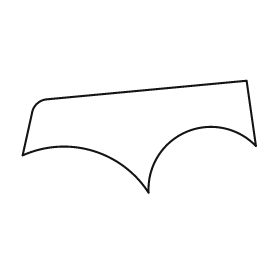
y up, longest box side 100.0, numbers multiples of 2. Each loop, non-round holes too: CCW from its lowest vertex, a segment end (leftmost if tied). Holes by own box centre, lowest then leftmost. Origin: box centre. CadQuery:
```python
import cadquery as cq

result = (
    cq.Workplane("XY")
    .moveTo(4.0, -24.0)
    .threePointArc((20.0, 2.0), (50.0, -4.0))
    .lineTo(46.0, 24.0)
    .lineTo(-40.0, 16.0)
    .threePointArc((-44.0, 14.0), (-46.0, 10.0))
    .lineTo(-50.0, -8.0)
    .threePointArc((-20.0, -6.0), (4.0, -24.0))
    .close()
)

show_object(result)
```